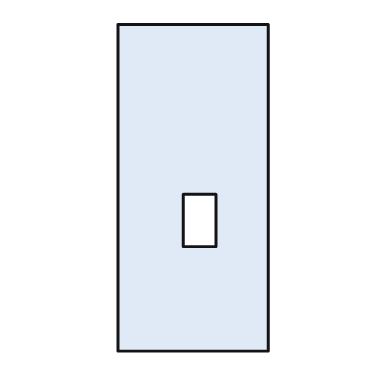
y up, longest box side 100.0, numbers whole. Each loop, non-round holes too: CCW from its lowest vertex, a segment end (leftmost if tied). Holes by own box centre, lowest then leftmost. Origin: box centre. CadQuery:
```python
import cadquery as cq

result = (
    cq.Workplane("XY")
    .moveTo(-23.0, -50.0)
    .lineTo(23.0, -50.0)
    .lineTo(23.0, 50.0)
    .lineTo(-23.0, 50.0)
    .close()
    .moveTo(-3.0, -18.0)
    .lineTo(7.0, -18.0)
    .lineTo(7.0, -2.0)
    .lineTo(-3.0, -2.0)
    .close()
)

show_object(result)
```